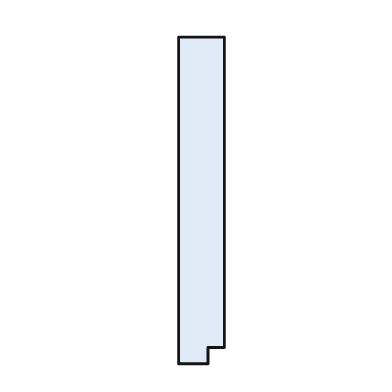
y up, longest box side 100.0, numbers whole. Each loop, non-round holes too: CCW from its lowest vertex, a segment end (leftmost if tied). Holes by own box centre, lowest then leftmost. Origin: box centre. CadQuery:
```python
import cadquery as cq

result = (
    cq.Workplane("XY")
    .moveTo(-7.0, -50.0)
    .lineTo(2.0, -50.0)
    .lineTo(2.0, -45.0)
    .lineTo(7.0, -45.0)
    .lineTo(7.0, 50.0)
    .lineTo(-7.0, 50.0)
    .close()
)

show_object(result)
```